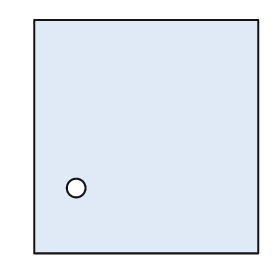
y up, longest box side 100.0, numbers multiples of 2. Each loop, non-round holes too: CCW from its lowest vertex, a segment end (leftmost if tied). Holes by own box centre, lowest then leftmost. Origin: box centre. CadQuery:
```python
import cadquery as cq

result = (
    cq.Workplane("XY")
    .moveTo(-48.0, -50.0)
    .lineTo(48.0, -50.0)
    .lineTo(48.0, 50.0)
    .lineTo(-48.0, 50.0)
    .close()
    .moveTo(-30.0, -22.0)
    .circle(4.0)
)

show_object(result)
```